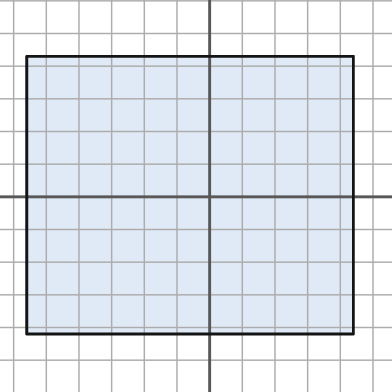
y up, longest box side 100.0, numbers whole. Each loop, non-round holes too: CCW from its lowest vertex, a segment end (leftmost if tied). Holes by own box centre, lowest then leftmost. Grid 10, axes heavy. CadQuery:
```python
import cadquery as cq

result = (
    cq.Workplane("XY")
    .moveTo(-56.0, -42.0)
    .lineTo(44.0, -42.0)
    .lineTo(44.0, 43.0)
    .lineTo(-56.0, 43.0)
    .close()
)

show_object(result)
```